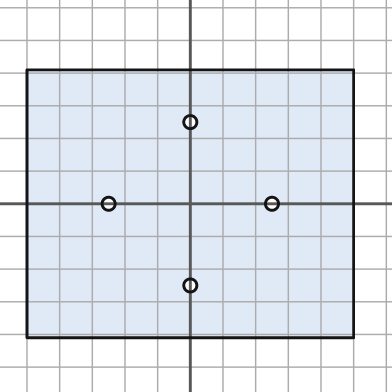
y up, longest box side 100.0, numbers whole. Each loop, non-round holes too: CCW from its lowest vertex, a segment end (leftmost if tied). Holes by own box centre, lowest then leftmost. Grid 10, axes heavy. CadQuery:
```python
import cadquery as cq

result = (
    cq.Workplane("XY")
    .moveTo(-50.0, -41.0)
    .lineTo(50.0, -41.0)
    .lineTo(50.0, 41.0)
    .lineTo(-50.0, 41.0)
    .close()
    .moveTo(0.0, -25.0)
    .circle(2.0)
    .moveTo(-25.0, 0.0)
    .circle(2.0)
    .moveTo(25.0, 0.0)
    .circle(2.0)
    .moveTo(0.0, 25.0)
    .circle(2.0)
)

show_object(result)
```